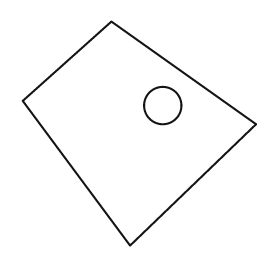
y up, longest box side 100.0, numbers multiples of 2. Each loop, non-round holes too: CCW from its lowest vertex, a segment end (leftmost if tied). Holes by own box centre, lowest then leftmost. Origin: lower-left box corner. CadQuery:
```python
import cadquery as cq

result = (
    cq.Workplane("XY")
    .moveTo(46.0, 0.0)
    .lineTo(100.0, 52.0)
    .lineTo(38.0, 96.0)
    .lineTo(0.0, 62.0)
    .close()
    .moveTo(60.0, 60.0)
    .circle(8.0)
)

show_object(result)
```